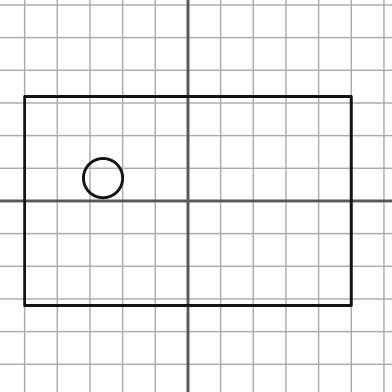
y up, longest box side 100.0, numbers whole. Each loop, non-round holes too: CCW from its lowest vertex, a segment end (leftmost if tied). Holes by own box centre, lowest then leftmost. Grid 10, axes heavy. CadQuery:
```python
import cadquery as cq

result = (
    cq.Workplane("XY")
    .moveTo(-50.0, -32.0)
    .lineTo(50.0, -32.0)
    .lineTo(50.0, 32.0)
    .lineTo(-50.0, 32.0)
    .close()
    .moveTo(-26.0, 7.0)
    .circle(6.0)
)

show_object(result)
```